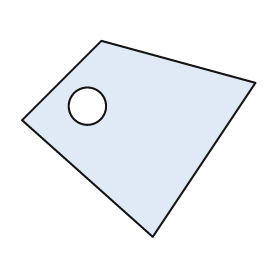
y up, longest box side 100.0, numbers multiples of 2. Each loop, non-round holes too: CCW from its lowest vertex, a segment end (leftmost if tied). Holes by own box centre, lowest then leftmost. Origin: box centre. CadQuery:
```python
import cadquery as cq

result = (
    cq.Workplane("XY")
    .moveTo(6.0, -42.0)
    .lineTo(50.0, 24.0)
    .lineTo(-16.0, 42.0)
    .lineTo(-50.0, 8.0)
    .close()
    .moveTo(-22.0, 14.0)
    .circle(8.0)
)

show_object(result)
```